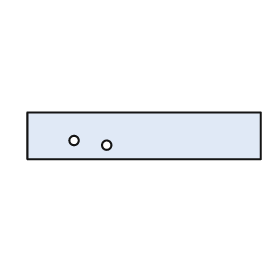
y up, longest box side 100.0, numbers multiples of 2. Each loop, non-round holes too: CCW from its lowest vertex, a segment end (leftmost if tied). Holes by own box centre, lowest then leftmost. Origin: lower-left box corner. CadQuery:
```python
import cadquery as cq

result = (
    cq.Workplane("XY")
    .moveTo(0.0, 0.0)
    .lineTo(100.0, 0.0)
    .lineTo(100.0, 20.0)
    .lineTo(0.0, 20.0)
    .close()
    .moveTo(34.0, 6.0)
    .circle(2.0)
    .moveTo(20.0, 8.0)
    .circle(2.0)
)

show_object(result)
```